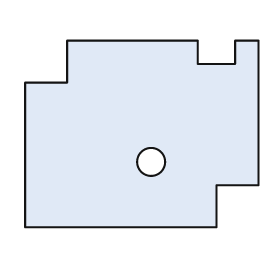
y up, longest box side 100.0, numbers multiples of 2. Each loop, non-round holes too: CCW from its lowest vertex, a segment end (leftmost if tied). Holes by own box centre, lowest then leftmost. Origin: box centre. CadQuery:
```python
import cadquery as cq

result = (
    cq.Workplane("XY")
    .moveTo(-50.0, -40.0)
    .lineTo(32.0, -40.0)
    .lineTo(32.0, -22.0)
    .lineTo(50.0, -22.0)
    .lineTo(50.0, 40.0)
    .lineTo(40.0, 40.0)
    .lineTo(40.0, 30.0)
    .lineTo(24.0, 30.0)
    .lineTo(24.0, 40.0)
    .lineTo(-32.0, 40.0)
    .lineTo(-32.0, 22.0)
    .lineTo(-50.0, 22.0)
    .close()
    .moveTo(4.0, -12.0)
    .circle(6.0)
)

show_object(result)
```